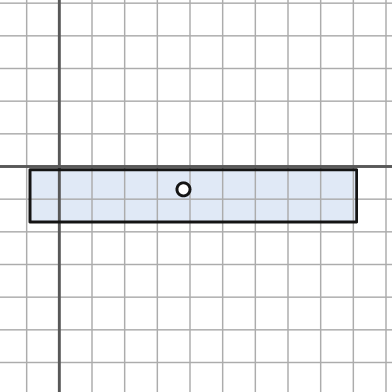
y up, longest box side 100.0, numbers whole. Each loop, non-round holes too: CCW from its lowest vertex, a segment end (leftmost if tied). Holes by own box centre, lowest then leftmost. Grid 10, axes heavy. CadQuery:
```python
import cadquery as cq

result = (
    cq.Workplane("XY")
    .moveTo(-9.0, -17.0)
    .lineTo(91.0, -17.0)
    .lineTo(91.0, -1.0)
    .lineTo(-9.0, -1.0)
    .close()
    .moveTo(38.0, -7.0)
    .circle(2.0)
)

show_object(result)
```